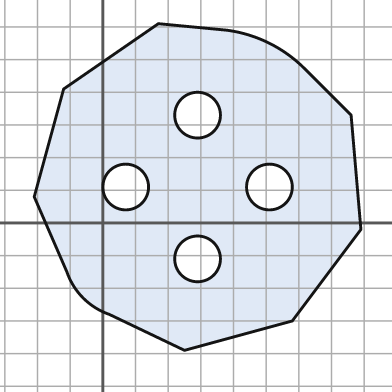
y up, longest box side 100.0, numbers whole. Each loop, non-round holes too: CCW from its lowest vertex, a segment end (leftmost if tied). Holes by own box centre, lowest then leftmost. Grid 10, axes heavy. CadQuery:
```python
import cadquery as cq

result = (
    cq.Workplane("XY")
    .moveTo(25.0, -39.0)
    .lineTo(58.0, -30.0)
    .lineTo(79.0, -2.0)
    .lineTo(76.0, 33.0)
    .lineTo(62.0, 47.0)
    .threePointArc((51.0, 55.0), (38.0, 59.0))
    .lineTo(17.0, 61.0)
    .lineTo(-12.0, 41.0)
    .lineTo(-21.0, 8.0)
    .lineTo(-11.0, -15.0)
    .threePointArc((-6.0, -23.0), (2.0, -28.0))
    .close()
    .moveTo(29.0, -11.0)
    .circle(7.0)
    .moveTo(7.0, 11.0)
    .circle(7.0)
    .moveTo(51.0, 11.0)
    .circle(7.0)
    .moveTo(29.0, 33.0)
    .circle(7.0)
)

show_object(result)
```